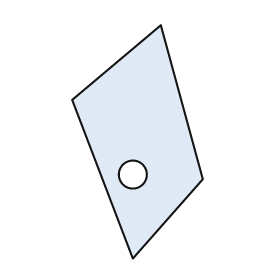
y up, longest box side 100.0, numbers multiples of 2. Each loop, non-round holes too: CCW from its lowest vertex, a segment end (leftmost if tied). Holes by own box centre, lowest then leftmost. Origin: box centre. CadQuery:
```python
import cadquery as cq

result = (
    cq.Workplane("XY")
    .moveTo(-2.0, -50.0)
    .lineTo(28.0, -16.0)
    .lineTo(10.0, 50.0)
    .lineTo(-28.0, 18.0)
    .close()
    .moveTo(-2.0, -14.0)
    .circle(6.0)
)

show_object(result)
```